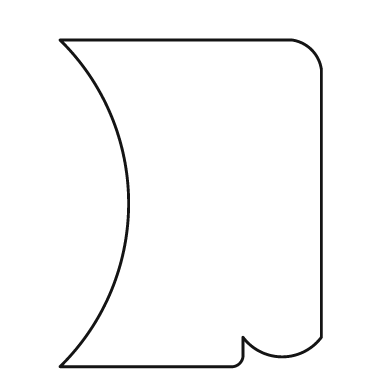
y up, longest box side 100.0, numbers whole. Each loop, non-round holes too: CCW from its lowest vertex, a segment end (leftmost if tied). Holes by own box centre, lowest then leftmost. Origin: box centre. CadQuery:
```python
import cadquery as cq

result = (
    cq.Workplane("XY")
    .moveTo(-40.0, -50.0)
    .lineTo(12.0, -50.0)
    .threePointArc((15.0, -49.0), (16.0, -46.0))
    .lineTo(16.0, -41.0)
    .threePointArc((28.0, -47.0), (40.0, -41.0))
    .lineTo(40.0, 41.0)
    .threePointArc((37.0, 47.0), (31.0, 50.0))
    .lineTo(-40.0, 50.0)
    .threePointArc((-19.0, 0.0), (-40.0, -50.0))
    .close()
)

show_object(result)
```